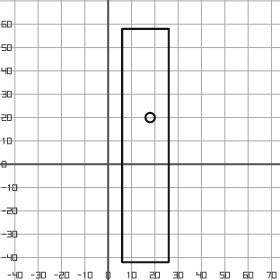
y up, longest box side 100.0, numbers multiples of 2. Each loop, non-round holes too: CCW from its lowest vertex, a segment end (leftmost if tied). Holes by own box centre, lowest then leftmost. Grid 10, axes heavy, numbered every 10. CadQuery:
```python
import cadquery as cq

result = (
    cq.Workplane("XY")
    .moveTo(6.0, -42.0)
    .lineTo(26.0, -42.0)
    .lineTo(26.0, 58.0)
    .lineTo(6.0, 58.0)
    .close()
    .moveTo(18.0, 20.0)
    .circle(2.0)
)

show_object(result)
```